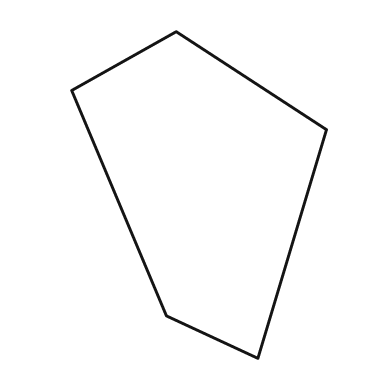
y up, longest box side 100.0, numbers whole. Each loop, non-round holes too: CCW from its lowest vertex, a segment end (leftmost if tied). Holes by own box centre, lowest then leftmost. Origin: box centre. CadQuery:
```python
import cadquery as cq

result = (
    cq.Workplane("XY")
    .moveTo(18.0, -50.0)
    .lineTo(39.0, 20.0)
    .lineTo(-7.0, 50.0)
    .lineTo(-39.0, 32.0)
    .lineTo(-10.0, -37.0)
    .close()
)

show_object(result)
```